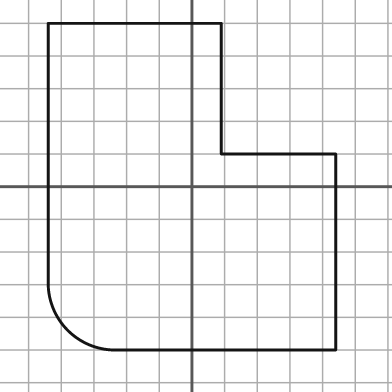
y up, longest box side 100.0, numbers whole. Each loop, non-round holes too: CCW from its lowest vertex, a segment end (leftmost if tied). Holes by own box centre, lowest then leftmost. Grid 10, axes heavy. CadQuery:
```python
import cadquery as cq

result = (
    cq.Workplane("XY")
    .moveTo(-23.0, -50.0)
    .lineTo(44.0, -50.0)
    .lineTo(44.0, 10.0)
    .lineTo(9.0, 10.0)
    .lineTo(9.0, 50.0)
    .lineTo(-44.0, 50.0)
    .lineTo(-44.0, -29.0)
    .threePointArc((-38.0, -44.0), (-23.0, -50.0))
    .close()
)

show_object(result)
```